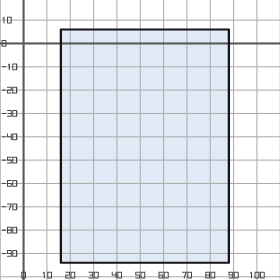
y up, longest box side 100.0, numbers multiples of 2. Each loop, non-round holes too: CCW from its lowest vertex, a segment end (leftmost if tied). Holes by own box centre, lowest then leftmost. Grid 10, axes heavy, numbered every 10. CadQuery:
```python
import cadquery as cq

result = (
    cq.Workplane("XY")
    .moveTo(16.0, -94.0)
    .lineTo(88.0, -94.0)
    .lineTo(88.0, 6.0)
    .lineTo(16.0, 6.0)
    .close()
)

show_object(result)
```